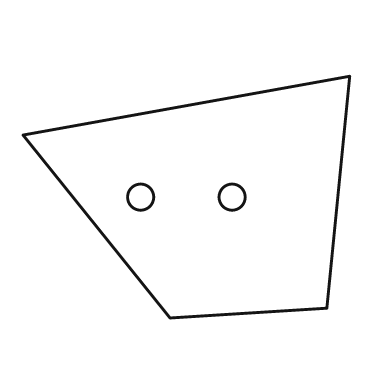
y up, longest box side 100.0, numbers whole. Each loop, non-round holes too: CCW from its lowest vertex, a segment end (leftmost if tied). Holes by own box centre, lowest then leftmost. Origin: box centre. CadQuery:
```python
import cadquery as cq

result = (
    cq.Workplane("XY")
    .moveTo(-5.0, -37.0)
    .lineTo(43.0, -34.0)
    .lineTo(50.0, 37.0)
    .lineTo(-50.0, 19.0)
    .close()
    .moveTo(-14.0, 0.0)
    .circle(4.0)
    .moveTo(14.0, 0.0)
    .circle(4.0)
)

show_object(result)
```